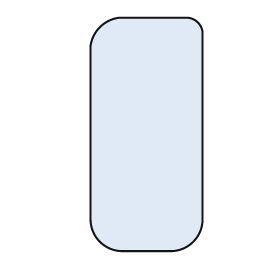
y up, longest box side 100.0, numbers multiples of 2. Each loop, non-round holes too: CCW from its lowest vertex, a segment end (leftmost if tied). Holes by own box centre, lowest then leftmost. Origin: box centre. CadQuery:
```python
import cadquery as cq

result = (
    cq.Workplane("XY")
    .moveTo(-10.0, -50.0)
    .lineTo(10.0, -50.0)
    .threePointArc((20.0, -46.0), (24.0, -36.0))
    .lineTo(24.0, 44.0)
    .threePointArc((22.0, 48.0), (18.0, 50.0))
    .lineTo(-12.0, 50.0)
    .threePointArc((-20.0, 46.0), (-24.0, 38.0))
    .lineTo(-24.0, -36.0)
    .threePointArc((-20.0, -46.0), (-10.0, -50.0))
    .close()
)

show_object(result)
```